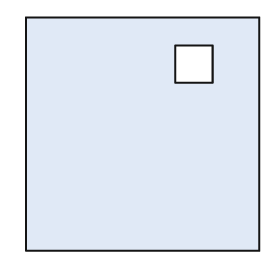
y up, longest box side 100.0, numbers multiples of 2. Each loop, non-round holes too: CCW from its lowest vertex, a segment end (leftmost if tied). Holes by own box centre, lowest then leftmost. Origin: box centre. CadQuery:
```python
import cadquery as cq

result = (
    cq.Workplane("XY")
    .moveTo(-50.0, -50.0)
    .lineTo(50.0, -50.0)
    .lineTo(50.0, 50.0)
    .lineTo(-50.0, 50.0)
    .close()
    .moveTo(14.0, 22.0)
    .lineTo(30.0, 22.0)
    .lineTo(30.0, 38.0)
    .lineTo(14.0, 38.0)
    .close()
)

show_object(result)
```